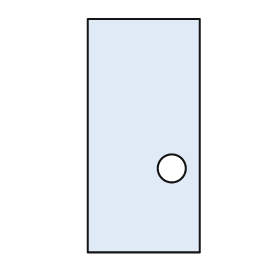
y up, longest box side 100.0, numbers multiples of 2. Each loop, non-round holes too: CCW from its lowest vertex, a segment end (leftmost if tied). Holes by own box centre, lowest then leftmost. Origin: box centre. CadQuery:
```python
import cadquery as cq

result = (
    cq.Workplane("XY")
    .moveTo(-24.0, -50.0)
    .lineTo(24.0, -50.0)
    .lineTo(24.0, 50.0)
    .lineTo(-24.0, 50.0)
    .close()
    .moveTo(12.0, -14.0)
    .circle(6.0)
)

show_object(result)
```